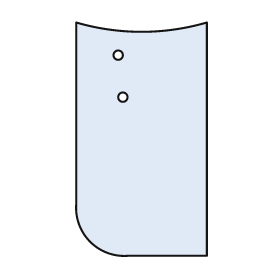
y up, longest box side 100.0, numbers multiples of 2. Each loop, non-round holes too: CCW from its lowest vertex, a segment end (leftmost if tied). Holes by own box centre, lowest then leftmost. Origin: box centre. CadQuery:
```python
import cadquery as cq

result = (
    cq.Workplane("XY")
    .moveTo(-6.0, -50.0)
    .lineTo(28.0, -50.0)
    .lineTo(28.0, 50.0)
    .threePointArc((0.0, 46.0), (-28.0, 50.0))
    .lineTo(-28.0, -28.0)
    .threePointArc((-22.0, -44.0), (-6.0, -50.0))
    .close()
    .moveTo(-8.0, 18.0)
    .circle(2.0)
    .moveTo(-10.0, 36.0)
    .circle(2.0)
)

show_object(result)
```